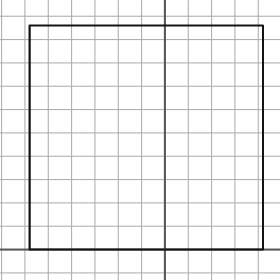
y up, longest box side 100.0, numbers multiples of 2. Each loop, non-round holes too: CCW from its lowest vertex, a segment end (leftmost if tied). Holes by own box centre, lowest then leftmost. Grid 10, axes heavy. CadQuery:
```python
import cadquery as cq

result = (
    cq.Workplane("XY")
    .moveTo(-58.0, 0.0)
    .lineTo(42.0, 0.0)
    .lineTo(42.0, 96.0)
    .lineTo(-58.0, 96.0)
    .close()
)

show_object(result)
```